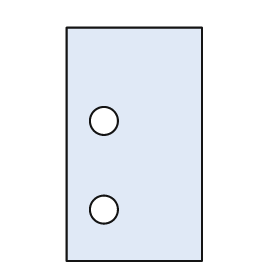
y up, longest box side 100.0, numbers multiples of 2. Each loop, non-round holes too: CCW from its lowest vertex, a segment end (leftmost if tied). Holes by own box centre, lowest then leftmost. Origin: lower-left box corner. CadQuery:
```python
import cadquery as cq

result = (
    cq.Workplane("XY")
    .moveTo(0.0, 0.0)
    .lineTo(58.0, 0.0)
    .lineTo(58.0, 100.0)
    .lineTo(0.0, 100.0)
    .close()
    .moveTo(16.0, 22.0)
    .circle(6.0)
    .moveTo(16.0, 60.0)
    .circle(6.0)
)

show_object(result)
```